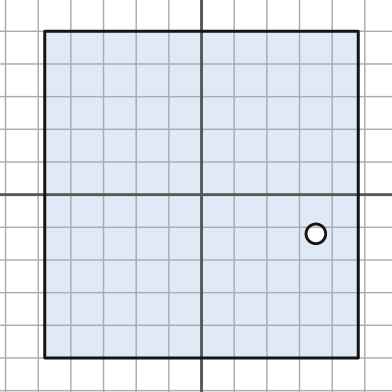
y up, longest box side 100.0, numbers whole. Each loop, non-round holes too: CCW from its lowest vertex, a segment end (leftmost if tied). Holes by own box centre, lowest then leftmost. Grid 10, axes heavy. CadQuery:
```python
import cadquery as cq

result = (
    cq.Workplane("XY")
    .moveTo(-48.0, -50.0)
    .lineTo(48.0, -50.0)
    .lineTo(48.0, 50.0)
    .lineTo(-48.0, 50.0)
    .close()
    .moveTo(35.0, -12.0)
    .circle(3.0)
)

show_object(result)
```